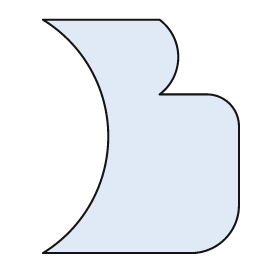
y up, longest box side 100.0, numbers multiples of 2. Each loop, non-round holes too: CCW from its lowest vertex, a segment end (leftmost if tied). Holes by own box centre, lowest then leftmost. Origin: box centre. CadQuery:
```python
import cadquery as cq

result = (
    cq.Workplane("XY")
    .moveTo(-42.0, -50.0)
    .lineTo(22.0, -50.0)
    .threePointArc((36.0, -44.0), (42.0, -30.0))
    .lineTo(42.0, 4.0)
    .threePointArc((38.0, 14.0), (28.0, 18.0))
    .lineTo(8.0, 18.0)
    .threePointArc((16.0, 34.0), (8.0, 50.0))
    .lineTo(-42.0, 50.0)
    .threePointArc((-14.0, 0.0), (-42.0, -50.0))
    .close()
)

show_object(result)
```